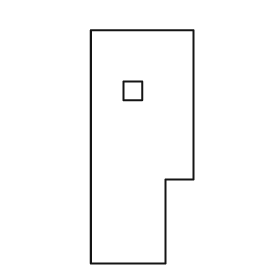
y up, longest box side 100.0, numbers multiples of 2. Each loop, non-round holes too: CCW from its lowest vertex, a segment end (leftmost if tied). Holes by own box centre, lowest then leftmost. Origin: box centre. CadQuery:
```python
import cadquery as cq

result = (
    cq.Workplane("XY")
    .moveTo(-22.0, -50.0)
    .lineTo(10.0, -50.0)
    .lineTo(10.0, -14.0)
    .lineTo(22.0, -14.0)
    .lineTo(22.0, 50.0)
    .lineTo(-22.0, 50.0)
    .close()
    .moveTo(-8.0, 20.0)
    .lineTo(0.0, 20.0)
    .lineTo(0.0, 28.0)
    .lineTo(-8.0, 28.0)
    .close()
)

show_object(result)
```